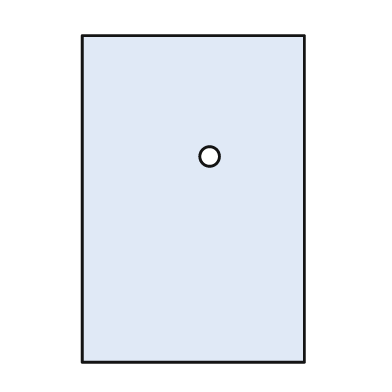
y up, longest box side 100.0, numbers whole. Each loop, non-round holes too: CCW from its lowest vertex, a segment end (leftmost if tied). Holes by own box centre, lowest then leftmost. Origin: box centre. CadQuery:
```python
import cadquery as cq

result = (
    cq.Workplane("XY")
    .moveTo(-34.0, -50.0)
    .lineTo(34.0, -50.0)
    .lineTo(34.0, 50.0)
    .lineTo(-34.0, 50.0)
    .close()
    .moveTo(5.0, 13.0)
    .circle(3.0)
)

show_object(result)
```